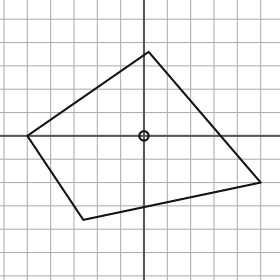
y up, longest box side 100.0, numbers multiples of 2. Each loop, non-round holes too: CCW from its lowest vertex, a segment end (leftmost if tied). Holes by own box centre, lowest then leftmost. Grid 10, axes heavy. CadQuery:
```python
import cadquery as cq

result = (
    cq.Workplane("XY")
    .moveTo(-26.0, -36.0)
    .lineTo(50.0, -20.0)
    .lineTo(2.0, 36.0)
    .lineTo(-50.0, 0.0)
    .close()
    .moveTo(0.0, 0.0)
    .circle(2.0)
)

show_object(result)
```